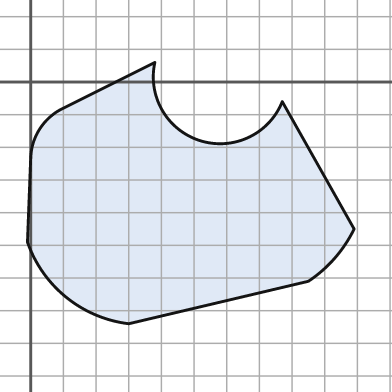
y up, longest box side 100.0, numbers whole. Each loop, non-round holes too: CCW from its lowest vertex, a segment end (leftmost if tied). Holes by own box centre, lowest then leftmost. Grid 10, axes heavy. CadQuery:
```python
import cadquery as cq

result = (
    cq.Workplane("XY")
    .moveTo(30.0, -74.0)
    .lineTo(85.0, -61.0)
    .threePointArc((93.0, -54.0), (99.0, -45.0))
    .lineTo(77.0, -6.0)
    .threePointArc((52.0, -18.0), (38.0, 6.0))
    .lineTo(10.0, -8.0)
    .threePointArc((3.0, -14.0), (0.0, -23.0))
    .lineTo(-1.0, -49.0)
    .threePointArc((11.0, -66.0), (30.0, -74.0))
    .close()
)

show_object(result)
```